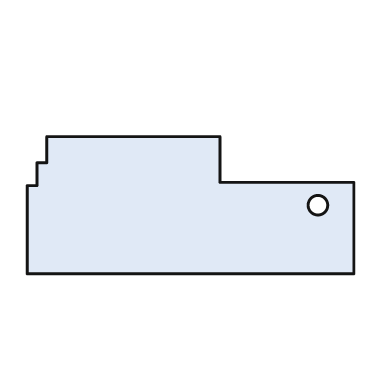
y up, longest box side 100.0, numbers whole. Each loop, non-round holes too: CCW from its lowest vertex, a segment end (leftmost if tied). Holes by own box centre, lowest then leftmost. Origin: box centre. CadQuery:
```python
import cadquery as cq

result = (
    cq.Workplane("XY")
    .moveTo(-50.0, -21.0)
    .lineTo(50.0, -21.0)
    .lineTo(50.0, 7.0)
    .lineTo(9.0, 7.0)
    .lineTo(9.0, 21.0)
    .lineTo(-44.0, 21.0)
    .lineTo(-44.0, 13.0)
    .lineTo(-47.0, 13.0)
    .lineTo(-47.0, 6.0)
    .lineTo(-50.0, 6.0)
    .close()
    .moveTo(39.0, 0.0)
    .circle(3.0)
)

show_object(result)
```